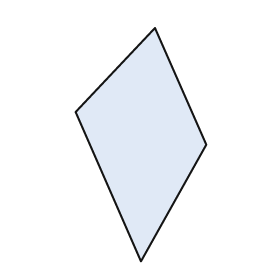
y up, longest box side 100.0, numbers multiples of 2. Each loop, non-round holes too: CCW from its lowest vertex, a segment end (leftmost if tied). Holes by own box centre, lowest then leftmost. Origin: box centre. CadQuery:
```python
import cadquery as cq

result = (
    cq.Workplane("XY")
    .moveTo(0.0, -50.0)
    .lineTo(28.0, 0.0)
    .lineTo(6.0, 50.0)
    .lineTo(-28.0, 14.0)
    .close()
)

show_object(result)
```